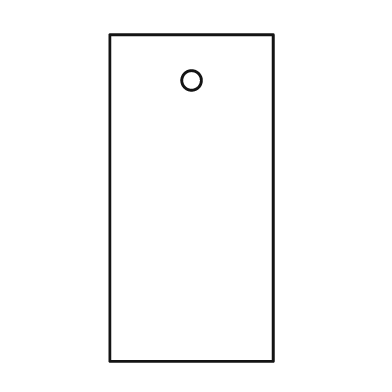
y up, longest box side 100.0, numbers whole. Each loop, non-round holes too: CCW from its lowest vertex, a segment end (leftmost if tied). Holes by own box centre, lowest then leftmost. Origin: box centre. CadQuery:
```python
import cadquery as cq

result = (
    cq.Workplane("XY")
    .moveTo(-25.0, -50.0)
    .lineTo(25.0, -50.0)
    .lineTo(25.0, 50.0)
    .lineTo(-25.0, 50.0)
    .close()
    .moveTo(0.0, 36.0)
    .circle(3.0)
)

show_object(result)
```